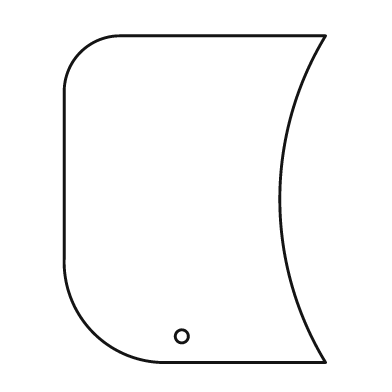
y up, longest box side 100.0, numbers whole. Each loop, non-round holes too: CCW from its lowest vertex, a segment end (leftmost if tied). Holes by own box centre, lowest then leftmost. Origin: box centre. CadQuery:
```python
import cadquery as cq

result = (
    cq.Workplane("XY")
    .moveTo(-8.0, -50.0)
    .lineTo(40.0, -50.0)
    .threePointArc((26.0, 0.0), (40.0, 50.0))
    .lineTo(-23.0, 50.0)
    .threePointArc((-35.0, 45.0), (-40.0, 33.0))
    .lineTo(-40.0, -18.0)
    .threePointArc((-31.0, -41.0), (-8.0, -50.0))
    .close()
    .moveTo(-4.0, -42.0)
    .circle(2.0)
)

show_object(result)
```